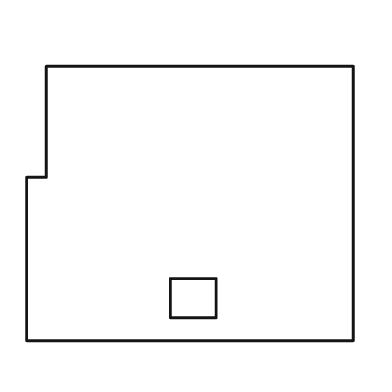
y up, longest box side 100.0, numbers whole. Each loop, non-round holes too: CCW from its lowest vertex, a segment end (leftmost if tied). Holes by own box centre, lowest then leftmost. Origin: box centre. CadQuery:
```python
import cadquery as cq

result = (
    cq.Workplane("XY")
    .moveTo(-50.0, -42.0)
    .lineTo(50.0, -42.0)
    .lineTo(50.0, 42.0)
    .lineTo(-44.0, 42.0)
    .lineTo(-44.0, 8.0)
    .lineTo(-50.0, 8.0)
    .close()
    .moveTo(-6.0, -35.0)
    .lineTo(8.0, -35.0)
    .lineTo(8.0, -23.0)
    .lineTo(-6.0, -23.0)
    .close()
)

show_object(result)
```